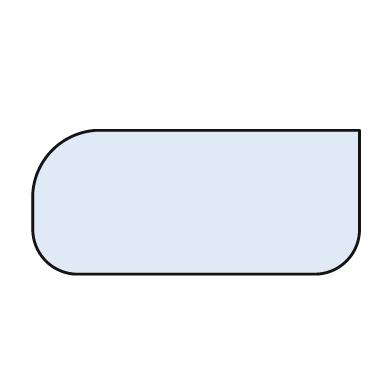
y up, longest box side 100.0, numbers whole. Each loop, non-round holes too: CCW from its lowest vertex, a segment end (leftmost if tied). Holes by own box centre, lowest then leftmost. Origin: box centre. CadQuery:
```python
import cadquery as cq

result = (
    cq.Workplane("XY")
    .moveTo(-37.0, -22.0)
    .lineTo(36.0, -22.0)
    .threePointArc((46.0, -18.0), (50.0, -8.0))
    .lineTo(50.0, 22.0)
    .lineTo(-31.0, 22.0)
    .threePointArc((-44.0, 16.0), (-50.0, 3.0))
    .lineTo(-50.0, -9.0)
    .threePointArc((-46.0, -18.0), (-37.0, -22.0))
    .close()
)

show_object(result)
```